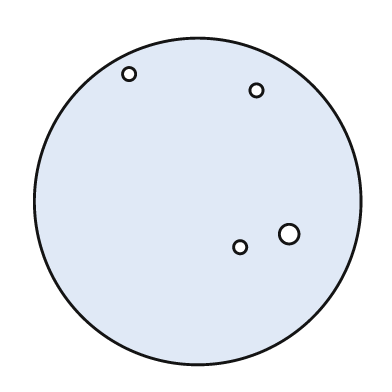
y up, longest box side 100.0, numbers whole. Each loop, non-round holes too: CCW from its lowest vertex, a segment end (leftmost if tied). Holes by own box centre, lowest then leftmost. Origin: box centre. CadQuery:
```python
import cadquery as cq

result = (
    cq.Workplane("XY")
    .moveTo(0.0, 0.0)
    .circle(50.0)
    .moveTo(13.0, -14.0)
    .circle(2.0)
    .moveTo(28.0, -10.0)
    .circle(3.0)
    .moveTo(18.0, 34.0)
    .circle(2.0)
    .moveTo(-21.0, 39.0)
    .circle(2.0)
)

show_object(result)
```